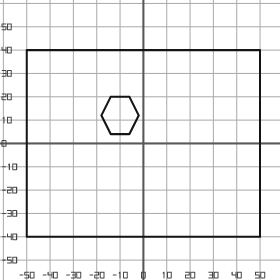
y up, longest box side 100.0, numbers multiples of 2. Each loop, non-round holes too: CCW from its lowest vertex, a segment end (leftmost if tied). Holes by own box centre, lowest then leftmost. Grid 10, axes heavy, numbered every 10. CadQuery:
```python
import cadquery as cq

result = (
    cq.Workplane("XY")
    .moveTo(-50.0, -40.0)
    .lineTo(50.0, -40.0)
    .lineTo(50.0, 40.0)
    .lineTo(-50.0, 40.0)
    .close()
    .moveTo(-14.0, 4.0)
    .lineTo(-6.0, 4.0)
    .lineTo(-2.0, 12.0)
    .lineTo(-6.0, 20.0)
    .lineTo(-14.0, 20.0)
    .lineTo(-18.0, 12.0)
    .close()
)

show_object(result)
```